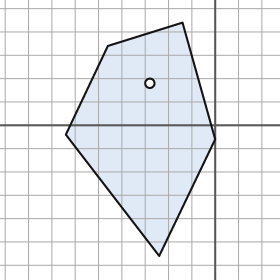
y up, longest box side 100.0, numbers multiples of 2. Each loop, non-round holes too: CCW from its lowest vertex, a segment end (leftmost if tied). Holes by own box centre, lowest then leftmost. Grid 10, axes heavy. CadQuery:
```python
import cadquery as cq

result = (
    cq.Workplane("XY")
    .moveTo(-24.0, -56.0)
    .lineTo(0.0, -6.0)
    .lineTo(-14.0, 44.0)
    .lineTo(-46.0, 34.0)
    .lineTo(-64.0, -4.0)
    .close()
    .moveTo(-28.0, 18.0)
    .circle(2.0)
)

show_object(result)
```